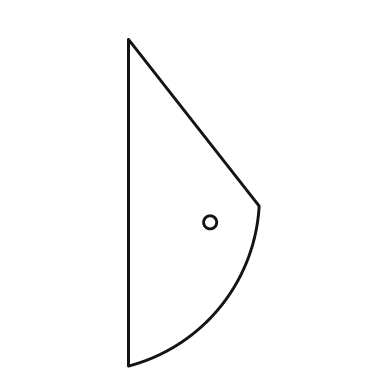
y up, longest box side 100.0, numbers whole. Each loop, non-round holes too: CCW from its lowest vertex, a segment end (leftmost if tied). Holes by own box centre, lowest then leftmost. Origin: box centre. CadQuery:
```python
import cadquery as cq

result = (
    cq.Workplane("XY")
    .moveTo(-20.0, -50.0)
    .threePointArc((8.0, -32.0), (20.0, -1.0))
    .lineTo(-20.0, 50.0)
    .close()
    .moveTo(5.0, -6.0)
    .circle(2.0)
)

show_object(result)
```